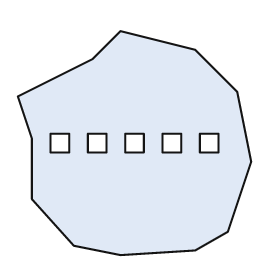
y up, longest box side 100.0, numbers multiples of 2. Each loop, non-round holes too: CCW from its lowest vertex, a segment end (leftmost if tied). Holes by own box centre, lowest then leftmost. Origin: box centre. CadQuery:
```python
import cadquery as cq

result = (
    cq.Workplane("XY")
    .moveTo(-6.0, -48.0)
    .lineTo(26.0, -46.0)
    .lineTo(40.0, -38.0)
    .lineTo(50.0, -8.0)
    .lineTo(44.0, 22.0)
    .lineTo(26.0, 40.0)
    .lineTo(-6.0, 48.0)
    .lineTo(-18.0, 36.0)
    .lineTo(-50.0, 20.0)
    .lineTo(-44.0, 2.0)
    .lineTo(-44.0, -24.0)
    .lineTo(-26.0, -44.0)
    .close()
    .moveTo(-36.0, -4.0)
    .lineTo(-28.0, -4.0)
    .lineTo(-28.0, 4.0)
    .lineTo(-36.0, 4.0)
    .close()
    .moveTo(-20.0, -4.0)
    .lineTo(-12.0, -4.0)
    .lineTo(-12.0, 4.0)
    .lineTo(-20.0, 4.0)
    .close()
    .moveTo(-4.0, -4.0)
    .lineTo(4.0, -4.0)
    .lineTo(4.0, 4.0)
    .lineTo(-4.0, 4.0)
    .close()
    .moveTo(12.0, -4.0)
    .lineTo(20.0, -4.0)
    .lineTo(20.0, 4.0)
    .lineTo(12.0, 4.0)
    .close()
    .moveTo(28.0, -4.0)
    .lineTo(36.0, -4.0)
    .lineTo(36.0, 4.0)
    .lineTo(28.0, 4.0)
    .close()
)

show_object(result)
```